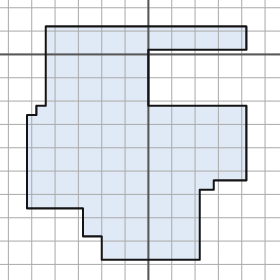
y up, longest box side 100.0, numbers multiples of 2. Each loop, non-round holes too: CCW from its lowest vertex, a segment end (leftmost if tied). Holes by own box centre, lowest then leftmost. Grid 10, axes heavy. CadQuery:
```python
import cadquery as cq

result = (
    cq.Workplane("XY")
    .moveTo(-20.0, -88.0)
    .lineTo(22.0, -88.0)
    .lineTo(22.0, -58.0)
    .lineTo(28.0, -58.0)
    .lineTo(28.0, -54.0)
    .lineTo(42.0, -54.0)
    .lineTo(42.0, -22.0)
    .lineTo(0.0, -22.0)
    .lineTo(0.0, 2.0)
    .lineTo(42.0, 2.0)
    .lineTo(42.0, 12.0)
    .lineTo(-44.0, 12.0)
    .lineTo(-44.0, -22.0)
    .lineTo(-48.0, -22.0)
    .lineTo(-48.0, -26.0)
    .lineTo(-52.0, -26.0)
    .lineTo(-52.0, -66.0)
    .lineTo(-28.0, -66.0)
    .lineTo(-28.0, -78.0)
    .lineTo(-20.0, -78.0)
    .close()
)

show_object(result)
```